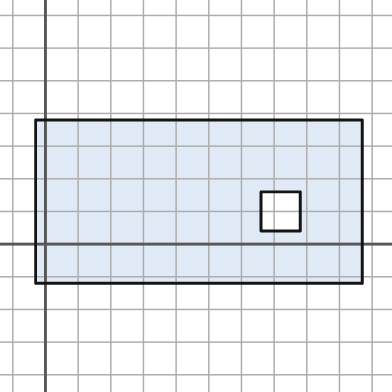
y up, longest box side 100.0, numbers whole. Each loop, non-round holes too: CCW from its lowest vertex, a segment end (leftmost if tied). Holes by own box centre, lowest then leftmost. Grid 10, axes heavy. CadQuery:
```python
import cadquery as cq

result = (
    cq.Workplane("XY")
    .moveTo(-3.0, -12.0)
    .lineTo(97.0, -12.0)
    .lineTo(97.0, 38.0)
    .lineTo(-3.0, 38.0)
    .close()
    .moveTo(66.0, 4.0)
    .lineTo(78.0, 4.0)
    .lineTo(78.0, 16.0)
    .lineTo(66.0, 16.0)
    .close()
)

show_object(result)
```